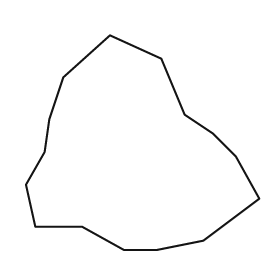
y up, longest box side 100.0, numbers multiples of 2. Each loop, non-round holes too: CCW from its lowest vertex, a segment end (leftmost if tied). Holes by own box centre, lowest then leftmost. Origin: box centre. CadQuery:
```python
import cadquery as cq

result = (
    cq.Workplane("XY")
    .moveTo(-8.0, -46.0)
    .lineTo(6.0, -46.0)
    .lineTo(26.0, -42.0)
    .lineTo(50.0, -24.0)
    .lineTo(40.0, -6.0)
    .lineTo(30.0, 4.0)
    .lineTo(18.0, 12.0)
    .lineTo(8.0, 36.0)
    .lineTo(-14.0, 46.0)
    .lineTo(-34.0, 28.0)
    .lineTo(-40.0, 10.0)
    .lineTo(-42.0, -4.0)
    .lineTo(-50.0, -18.0)
    .lineTo(-46.0, -36.0)
    .lineTo(-26.0, -36.0)
    .close()
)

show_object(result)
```